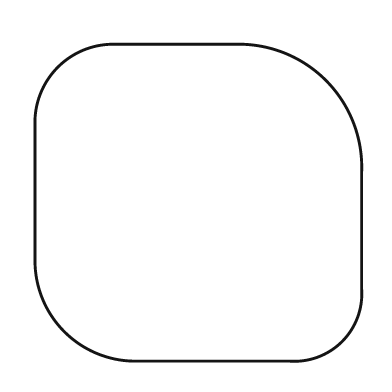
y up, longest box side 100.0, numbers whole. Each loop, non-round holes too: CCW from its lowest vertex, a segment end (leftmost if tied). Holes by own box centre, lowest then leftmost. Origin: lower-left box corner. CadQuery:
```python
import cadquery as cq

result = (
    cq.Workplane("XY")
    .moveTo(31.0, 0.0)
    .lineTo(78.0, 0.0)
    .threePointArc((94.0, 6.0), (100.0, 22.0))
    .lineTo(100.0, 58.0)
    .threePointArc((89.0, 86.0), (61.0, 97.0))
    .lineTo(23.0, 97.0)
    .threePointArc((7.0, 90.0), (0.0, 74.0))
    .lineTo(0.0, 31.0)
    .threePointArc((9.0, 9.0), (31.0, 0.0))
    .close()
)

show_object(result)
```